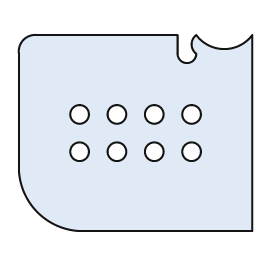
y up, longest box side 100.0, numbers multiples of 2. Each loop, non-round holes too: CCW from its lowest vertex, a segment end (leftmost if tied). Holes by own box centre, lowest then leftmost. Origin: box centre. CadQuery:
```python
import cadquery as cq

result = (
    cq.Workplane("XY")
    .moveTo(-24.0, -42.0)
    .lineTo(50.0, -42.0)
    .lineTo(50.0, 42.0)
    .threePointArc((38.0, 36.0), (26.0, 42.0))
    .threePointArc((24.0, 38.0), (26.0, 34.0))
    .threePointArc((22.0, 30.0), (18.0, 34.0))
    .lineTo(18.0, 42.0)
    .lineTo(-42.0, 42.0)
    .threePointArc((-48.0, 40.0), (-50.0, 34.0))
    .lineTo(-50.0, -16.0)
    .threePointArc((-42.0, -34.0), (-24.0, -42.0))
    .close()
    .moveTo(-24.0, -8.0)
    .circle(4.0)
    .moveTo(-8.0, -8.0)
    .circle(4.0)
    .moveTo(8.0, -8.0)
    .circle(4.0)
    .moveTo(24.0, -8.0)
    .circle(4.0)
    .moveTo(-24.0, 8.0)
    .circle(4.0)
    .moveTo(-8.0, 8.0)
    .circle(4.0)
    .moveTo(8.0, 8.0)
    .circle(4.0)
    .moveTo(24.0, 8.0)
    .circle(4.0)
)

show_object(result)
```